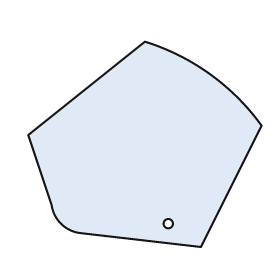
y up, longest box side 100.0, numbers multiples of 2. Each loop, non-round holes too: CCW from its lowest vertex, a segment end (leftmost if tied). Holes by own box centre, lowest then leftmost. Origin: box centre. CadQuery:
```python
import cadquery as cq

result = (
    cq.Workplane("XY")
    .moveTo(24.0, -44.0)
    .lineTo(50.0, 8.0)
    .threePointArc((28.0, 30.0), (0.0, 44.0))
    .lineTo(-50.0, 4.0)
    .lineTo(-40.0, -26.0)
    .threePointArc((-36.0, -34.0), (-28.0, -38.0))
    .close()
    .moveTo(10.0, -34.0)
    .circle(2.0)
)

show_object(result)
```